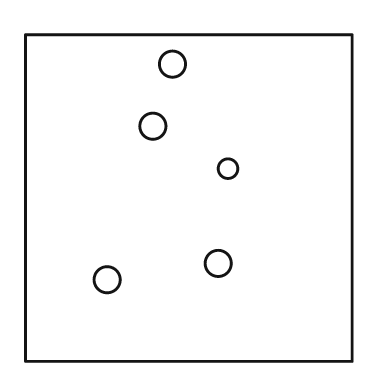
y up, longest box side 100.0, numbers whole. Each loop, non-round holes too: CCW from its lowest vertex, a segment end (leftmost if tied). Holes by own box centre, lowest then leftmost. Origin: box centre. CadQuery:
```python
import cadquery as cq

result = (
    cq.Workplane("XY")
    .moveTo(-50.0, -50.0)
    .lineTo(50.0, -50.0)
    .lineTo(50.0, 50.0)
    .lineTo(-50.0, 50.0)
    .close()
    .moveTo(-25.0, -25.0)
    .circle(4.0)
    .moveTo(9.0, -20.0)
    .circle(4.0)
    .moveTo(12.0, 9.0)
    .circle(3.0)
    .moveTo(-11.0, 22.0)
    .circle(4.0)
    .moveTo(-5.0, 41.0)
    .circle(4.0)
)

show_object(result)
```